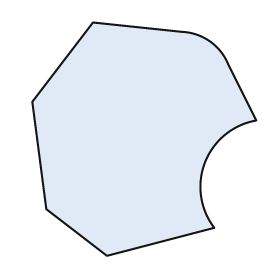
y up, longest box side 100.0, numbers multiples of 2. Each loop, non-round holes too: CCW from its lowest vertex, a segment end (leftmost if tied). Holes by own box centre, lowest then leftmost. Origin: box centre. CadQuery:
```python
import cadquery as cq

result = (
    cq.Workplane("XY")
    .moveTo(-16.0, -50.0)
    .lineTo(30.0, -38.0)
    .threePointArc((26.0, -10.0), (48.0, 8.0))
    .lineTo(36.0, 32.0)
    .threePointArc((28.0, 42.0), (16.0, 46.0))
    .lineTo(-22.0, 50.0)
    .lineTo(-48.0, 16.0)
    .lineTo(-42.0, -30.0)
    .close()
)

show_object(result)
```